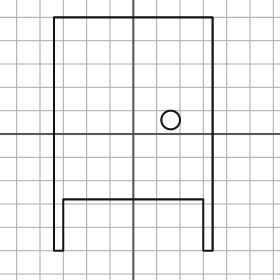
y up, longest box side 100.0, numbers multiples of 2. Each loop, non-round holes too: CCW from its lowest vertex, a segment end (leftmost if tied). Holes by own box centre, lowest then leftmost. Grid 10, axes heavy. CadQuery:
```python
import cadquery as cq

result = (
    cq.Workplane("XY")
    .moveTo(-34.0, -50.0)
    .lineTo(-30.0, -50.0)
    .lineTo(-30.0, -28.0)
    .lineTo(30.0, -28.0)
    .lineTo(30.0, -50.0)
    .lineTo(34.0, -50.0)
    .lineTo(34.0, 50.0)
    .lineTo(-34.0, 50.0)
    .close()
    .moveTo(16.0, 6.0)
    .circle(4.0)
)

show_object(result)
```